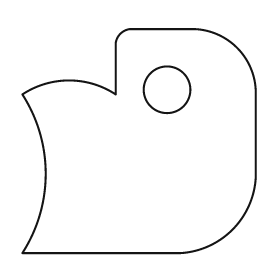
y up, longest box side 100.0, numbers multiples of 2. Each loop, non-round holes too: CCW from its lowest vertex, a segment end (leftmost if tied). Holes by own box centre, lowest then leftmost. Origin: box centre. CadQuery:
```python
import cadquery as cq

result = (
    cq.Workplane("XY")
    .moveTo(-50.0, -48.0)
    .lineTo(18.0, -48.0)
    .threePointArc((40.0, -38.0), (50.0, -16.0))
    .lineTo(50.0, 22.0)
    .threePointArc((42.0, 40.0), (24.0, 48.0))
    .lineTo(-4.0, 48.0)
    .threePointArc((-8.0, 46.0), (-10.0, 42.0))
    .lineTo(-10.0, 20.0)
    .threePointArc((-30.0, 26.0), (-50.0, 20.0))
    .threePointArc((-40.0, -14.0), (-50.0, -48.0))
    .close()
    .moveTo(12.0, 22.0)
    .circle(10.0)
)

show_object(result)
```